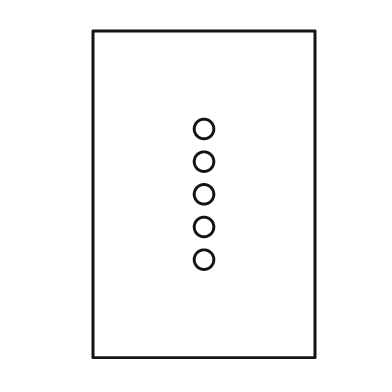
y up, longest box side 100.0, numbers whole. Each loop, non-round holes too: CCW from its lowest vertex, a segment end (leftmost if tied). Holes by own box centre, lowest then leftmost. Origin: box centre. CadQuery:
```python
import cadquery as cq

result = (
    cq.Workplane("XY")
    .moveTo(-34.0, -50.0)
    .lineTo(34.0, -50.0)
    .lineTo(34.0, 50.0)
    .lineTo(-34.0, 50.0)
    .close()
    .moveTo(0.0, -20.0)
    .circle(3.0)
    .moveTo(0.0, -10.0)
    .circle(3.0)
    .moveTo(0.0, 0.0)
    .circle(3.0)
    .moveTo(0.0, 10.0)
    .circle(3.0)
    .moveTo(0.0, 20.0)
    .circle(3.0)
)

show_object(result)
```